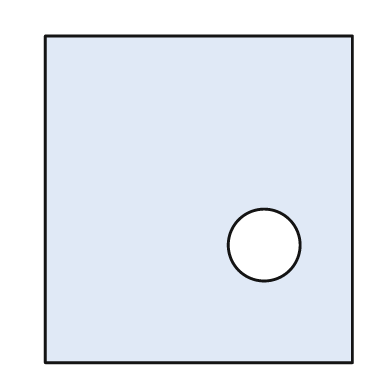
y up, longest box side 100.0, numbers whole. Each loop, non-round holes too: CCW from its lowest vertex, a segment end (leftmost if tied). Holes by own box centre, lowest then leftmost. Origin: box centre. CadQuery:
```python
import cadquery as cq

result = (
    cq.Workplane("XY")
    .moveTo(-47.0, -50.0)
    .lineTo(47.0, -50.0)
    .lineTo(47.0, 50.0)
    .lineTo(-47.0, 50.0)
    .close()
    .moveTo(20.0, -14.0)
    .circle(11.0)
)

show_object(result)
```